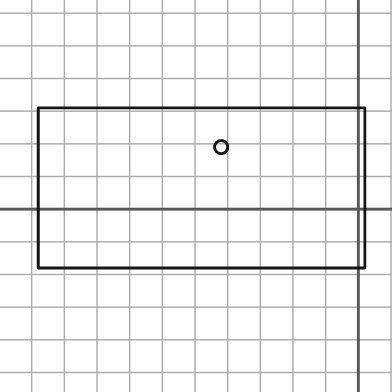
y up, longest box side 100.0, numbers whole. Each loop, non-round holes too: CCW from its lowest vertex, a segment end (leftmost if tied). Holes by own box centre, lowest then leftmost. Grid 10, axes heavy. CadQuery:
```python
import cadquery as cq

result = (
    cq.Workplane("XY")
    .moveTo(-98.0, -18.0)
    .lineTo(2.0, -18.0)
    .lineTo(2.0, 31.0)
    .lineTo(-98.0, 31.0)
    .close()
    .moveTo(-42.0, 19.0)
    .circle(2.0)
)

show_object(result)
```